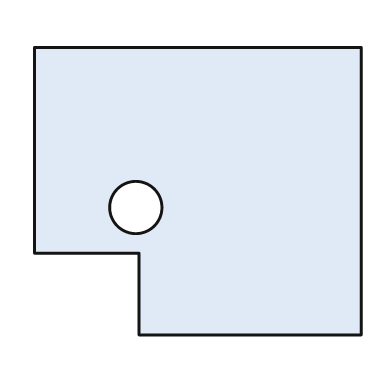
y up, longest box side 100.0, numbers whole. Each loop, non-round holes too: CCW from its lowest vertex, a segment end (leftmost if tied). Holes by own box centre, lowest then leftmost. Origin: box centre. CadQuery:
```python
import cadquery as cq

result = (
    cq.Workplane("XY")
    .moveTo(-18.0, -44.0)
    .lineTo(50.0, -44.0)
    .lineTo(50.0, 44.0)
    .lineTo(-50.0, 44.0)
    .lineTo(-50.0, -19.0)
    .lineTo(-18.0, -19.0)
    .close()
    .moveTo(-19.0, -5.0)
    .circle(8.0)
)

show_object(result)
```